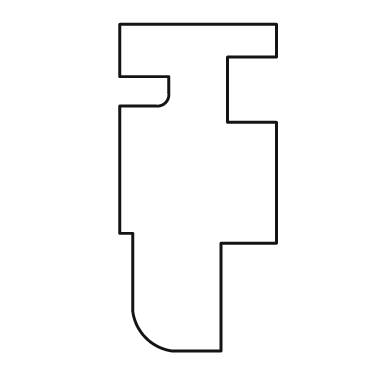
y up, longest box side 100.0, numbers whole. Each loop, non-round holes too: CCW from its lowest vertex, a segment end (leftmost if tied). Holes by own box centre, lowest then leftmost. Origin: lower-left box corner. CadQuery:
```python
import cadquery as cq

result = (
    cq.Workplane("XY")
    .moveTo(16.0, 0.0)
    .lineTo(31.0, 0.0)
    .lineTo(31.0, 33.0)
    .lineTo(48.0, 33.0)
    .lineTo(48.0, 70.0)
    .lineTo(33.0, 70.0)
    .lineTo(33.0, 90.0)
    .lineTo(48.0, 90.0)
    .lineTo(48.0, 100.0)
    .lineTo(0.0, 100.0)
    .lineTo(0.0, 84.0)
    .lineTo(15.0, 84.0)
    .lineTo(15.0, 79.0)
    .threePointArc((14.0, 76.0), (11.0, 75.0))
    .lineTo(0.0, 75.0)
    .lineTo(0.0, 36.0)
    .lineTo(4.0, 36.0)
    .lineTo(4.0, 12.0)
    .threePointArc((8.0, 4.0), (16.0, 0.0))
    .close()
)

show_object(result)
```